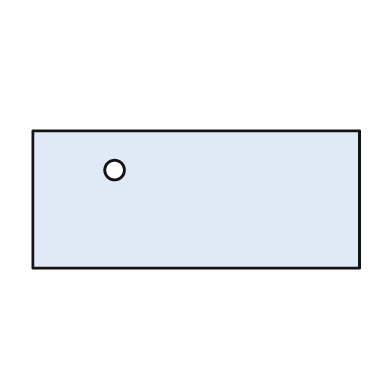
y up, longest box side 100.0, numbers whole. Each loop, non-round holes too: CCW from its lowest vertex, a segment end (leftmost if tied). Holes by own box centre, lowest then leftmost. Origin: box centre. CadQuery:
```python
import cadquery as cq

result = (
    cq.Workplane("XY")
    .moveTo(-50.0, -21.0)
    .lineTo(50.0, -21.0)
    .lineTo(50.0, 21.0)
    .lineTo(-50.0, 21.0)
    .close()
    .moveTo(-25.0, 9.0)
    .circle(3.0)
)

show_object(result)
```